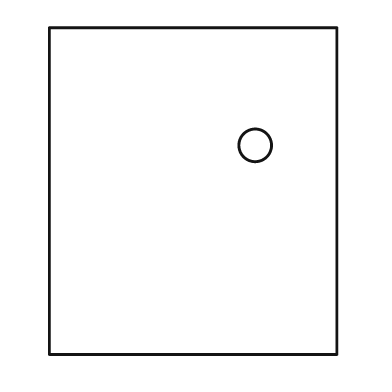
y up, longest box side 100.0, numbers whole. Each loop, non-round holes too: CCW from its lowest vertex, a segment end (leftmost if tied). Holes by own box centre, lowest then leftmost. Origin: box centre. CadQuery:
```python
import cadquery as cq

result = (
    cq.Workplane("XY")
    .moveTo(-44.0, -50.0)
    .lineTo(44.0, -50.0)
    .lineTo(44.0, 50.0)
    .lineTo(-44.0, 50.0)
    .close()
    .moveTo(19.0, 14.0)
    .circle(5.0)
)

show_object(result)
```